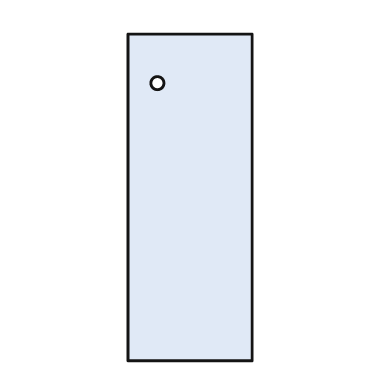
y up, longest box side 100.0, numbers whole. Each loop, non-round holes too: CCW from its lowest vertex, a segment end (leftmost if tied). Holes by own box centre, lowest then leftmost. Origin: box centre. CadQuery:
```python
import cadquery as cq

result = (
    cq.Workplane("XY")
    .moveTo(-19.0, -50.0)
    .lineTo(19.0, -50.0)
    .lineTo(19.0, 50.0)
    .lineTo(-19.0, 50.0)
    .close()
    .moveTo(-10.0, 35.0)
    .circle(2.0)
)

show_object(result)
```